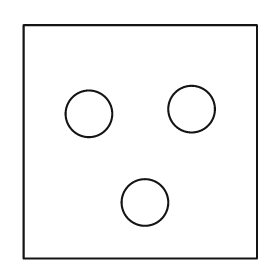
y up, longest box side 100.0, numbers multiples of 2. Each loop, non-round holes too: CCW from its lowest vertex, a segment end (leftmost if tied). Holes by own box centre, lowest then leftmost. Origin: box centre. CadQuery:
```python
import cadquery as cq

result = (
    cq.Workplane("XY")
    .moveTo(-50.0, -50.0)
    .lineTo(50.0, -50.0)
    .lineTo(50.0, 50.0)
    .lineTo(-50.0, 50.0)
    .close()
    .moveTo(2.0, -26.0)
    .circle(10.0)
    .moveTo(-22.0, 12.0)
    .circle(10.0)
    .moveTo(22.0, 14.0)
    .circle(10.0)
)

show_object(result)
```